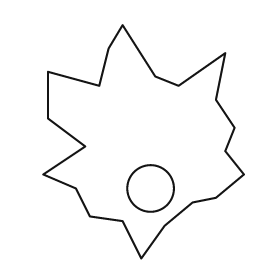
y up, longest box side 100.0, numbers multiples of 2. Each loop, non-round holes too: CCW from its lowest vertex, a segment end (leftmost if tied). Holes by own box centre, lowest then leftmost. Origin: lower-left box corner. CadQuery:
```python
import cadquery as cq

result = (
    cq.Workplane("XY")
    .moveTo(42.0, 0.0)
    .lineTo(52.0, 14.0)
    .lineTo(64.0, 24.0)
    .lineTo(74.0, 26.0)
    .lineTo(86.0, 36.0)
    .lineTo(78.0, 46.0)
    .lineTo(82.0, 56.0)
    .lineTo(74.0, 68.0)
    .lineTo(78.0, 88.0)
    .lineTo(58.0, 74.0)
    .lineTo(48.0, 78.0)
    .lineTo(34.0, 100.0)
    .lineTo(28.0, 90.0)
    .lineTo(24.0, 74.0)
    .lineTo(2.0, 80.0)
    .lineTo(2.0, 60.0)
    .lineTo(18.0, 48.0)
    .lineTo(0.0, 36.0)
    .lineTo(14.0, 30.0)
    .lineTo(20.0, 18.0)
    .lineTo(34.0, 16.0)
    .close()
    .moveTo(46.0, 30.0)
    .circle(10.0)
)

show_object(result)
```